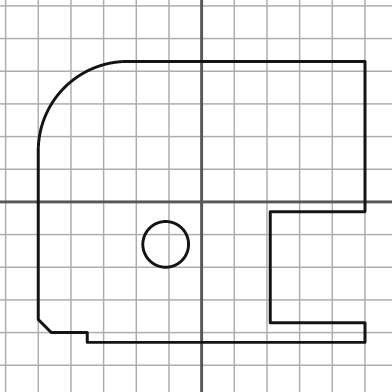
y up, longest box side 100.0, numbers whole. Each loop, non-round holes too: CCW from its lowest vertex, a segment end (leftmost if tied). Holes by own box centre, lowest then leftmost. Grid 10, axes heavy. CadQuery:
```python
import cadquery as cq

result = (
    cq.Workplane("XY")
    .moveTo(-35.0, -43.0)
    .lineTo(50.0, -43.0)
    .lineTo(50.0, -37.0)
    .lineTo(21.0, -37.0)
    .lineTo(21.0, -3.0)
    .lineTo(50.0, -3.0)
    .lineTo(50.0, 43.0)
    .lineTo(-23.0, 43.0)
    .threePointArc((-42.0, 35.0), (-50.0, 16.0))
    .lineTo(-50.0, -36.0)
    .lineTo(-46.0, -40.0)
    .lineTo(-35.0, -40.0)
    .close()
    .moveTo(-11.0, -13.0)
    .circle(7.0)
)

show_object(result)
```